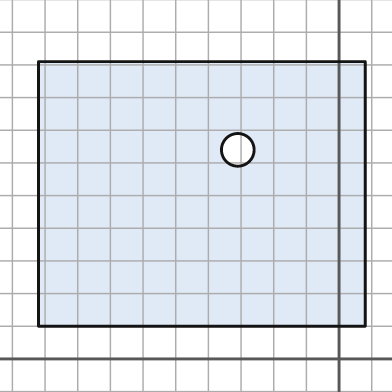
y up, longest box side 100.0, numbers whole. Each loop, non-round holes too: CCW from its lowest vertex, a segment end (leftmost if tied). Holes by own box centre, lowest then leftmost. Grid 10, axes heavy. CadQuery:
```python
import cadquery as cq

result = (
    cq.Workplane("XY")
    .moveTo(-92.0, 10.0)
    .lineTo(8.0, 10.0)
    .lineTo(8.0, 91.0)
    .lineTo(-92.0, 91.0)
    .close()
    .moveTo(-31.0, 64.0)
    .circle(5.0)
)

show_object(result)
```